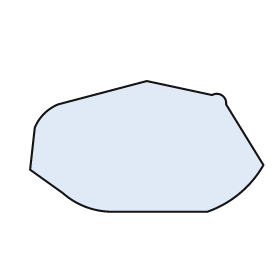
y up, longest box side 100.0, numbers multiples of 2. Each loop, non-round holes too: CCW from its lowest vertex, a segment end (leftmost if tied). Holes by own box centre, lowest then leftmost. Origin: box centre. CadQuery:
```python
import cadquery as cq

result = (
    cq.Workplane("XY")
    .moveTo(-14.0, -28.0)
    .lineTo(26.0, -28.0)
    .threePointArc((40.0, -20.0), (50.0, -8.0))
    .lineTo(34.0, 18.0)
    .threePointArc((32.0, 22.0), (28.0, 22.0))
    .lineTo(0.0, 28.0)
    .lineTo(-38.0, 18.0)
    .threePointArc((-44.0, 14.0), (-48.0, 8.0))
    .lineTo(-50.0, -10.0)
    .lineTo(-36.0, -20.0)
    .threePointArc((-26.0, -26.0), (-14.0, -28.0))
    .close()
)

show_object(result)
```